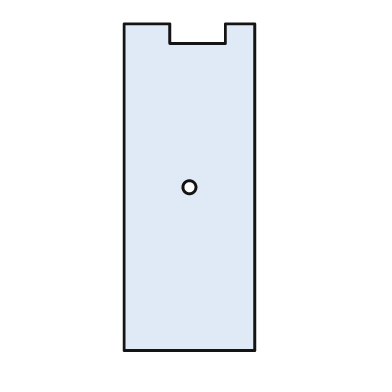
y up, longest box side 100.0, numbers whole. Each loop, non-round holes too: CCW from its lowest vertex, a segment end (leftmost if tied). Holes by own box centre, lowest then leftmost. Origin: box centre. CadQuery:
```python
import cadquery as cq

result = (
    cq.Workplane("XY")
    .moveTo(-20.0, -50.0)
    .lineTo(20.0, -50.0)
    .lineTo(20.0, 50.0)
    .lineTo(11.0, 50.0)
    .lineTo(11.0, 44.0)
    .lineTo(-6.0, 44.0)
    .lineTo(-6.0, 50.0)
    .lineTo(-20.0, 50.0)
    .close()
    .moveTo(0.0, 0.0)
    .circle(2.0)
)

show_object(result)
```